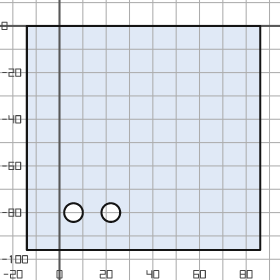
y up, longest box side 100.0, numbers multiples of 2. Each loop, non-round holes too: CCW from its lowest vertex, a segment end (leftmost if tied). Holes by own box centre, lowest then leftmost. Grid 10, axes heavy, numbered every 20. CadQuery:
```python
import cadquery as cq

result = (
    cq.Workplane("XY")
    .moveTo(-14.0, -96.0)
    .lineTo(86.0, -96.0)
    .lineTo(86.0, 0.0)
    .lineTo(-14.0, 0.0)
    .close()
    .moveTo(6.0, -80.0)
    .circle(4.0)
    .moveTo(22.0, -80.0)
    .circle(4.0)
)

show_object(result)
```